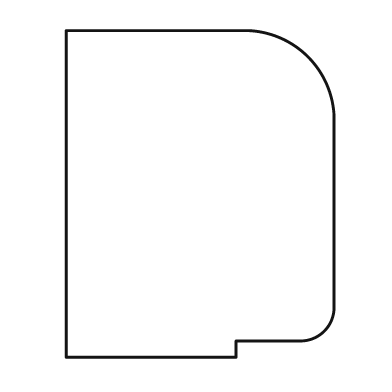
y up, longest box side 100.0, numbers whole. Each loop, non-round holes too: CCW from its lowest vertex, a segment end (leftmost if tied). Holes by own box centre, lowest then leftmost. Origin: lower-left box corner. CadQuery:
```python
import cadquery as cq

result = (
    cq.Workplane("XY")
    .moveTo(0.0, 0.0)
    .lineTo(52.0, 0.0)
    .lineTo(52.0, 5.0)
    .lineTo(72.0, 5.0)
    .threePointArc((79.0, 8.0), (82.0, 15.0))
    .lineTo(82.0, 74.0)
    .threePointArc((74.0, 92.0), (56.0, 100.0))
    .lineTo(0.0, 100.0)
    .close()
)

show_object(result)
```